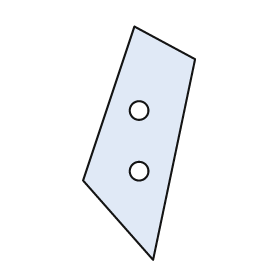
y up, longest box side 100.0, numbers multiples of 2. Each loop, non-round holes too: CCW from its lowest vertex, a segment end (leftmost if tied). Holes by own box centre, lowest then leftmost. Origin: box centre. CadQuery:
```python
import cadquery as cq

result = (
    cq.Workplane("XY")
    .moveTo(6.0, -50.0)
    .lineTo(24.0, 36.0)
    .lineTo(-2.0, 50.0)
    .lineTo(-24.0, -16.0)
    .close()
    .moveTo(0.0, -12.0)
    .circle(4.0)
    .moveTo(0.0, 14.0)
    .circle(4.0)
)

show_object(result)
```